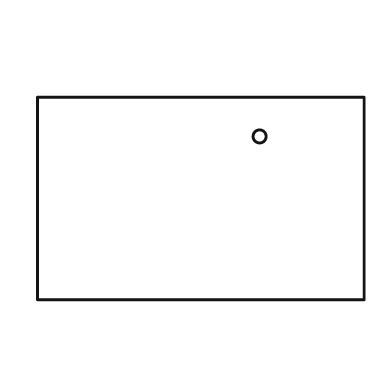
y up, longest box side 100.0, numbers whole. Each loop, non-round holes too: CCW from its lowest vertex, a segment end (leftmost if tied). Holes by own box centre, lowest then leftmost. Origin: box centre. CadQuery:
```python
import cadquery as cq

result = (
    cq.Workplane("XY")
    .moveTo(-50.0, -31.0)
    .lineTo(50.0, -31.0)
    .lineTo(50.0, 31.0)
    .lineTo(-50.0, 31.0)
    .close()
    .moveTo(18.0, 19.0)
    .circle(2.0)
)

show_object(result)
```